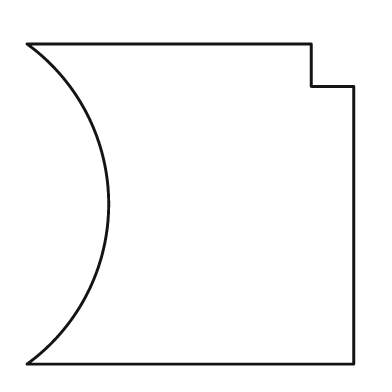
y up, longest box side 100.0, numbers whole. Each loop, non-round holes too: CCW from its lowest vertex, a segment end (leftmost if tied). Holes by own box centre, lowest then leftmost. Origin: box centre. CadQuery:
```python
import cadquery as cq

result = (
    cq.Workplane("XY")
    .moveTo(-50.0, -49.0)
    .lineTo(50.0, -49.0)
    .lineTo(50.0, 36.0)
    .lineTo(37.0, 36.0)
    .lineTo(37.0, 49.0)
    .lineTo(-50.0, 49.0)
    .threePointArc((-25.0, 0.0), (-50.0, -49.0))
    .close()
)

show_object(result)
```